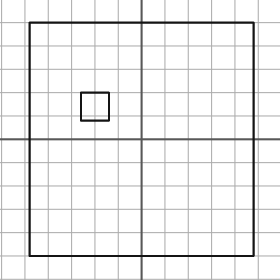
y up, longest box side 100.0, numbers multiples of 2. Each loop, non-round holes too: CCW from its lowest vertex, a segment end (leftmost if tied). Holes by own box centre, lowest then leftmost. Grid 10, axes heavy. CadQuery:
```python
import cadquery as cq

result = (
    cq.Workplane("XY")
    .moveTo(-48.0, -50.0)
    .lineTo(48.0, -50.0)
    .lineTo(48.0, 50.0)
    .lineTo(-48.0, 50.0)
    .close()
    .moveTo(-26.0, 8.0)
    .lineTo(-14.0, 8.0)
    .lineTo(-14.0, 20.0)
    .lineTo(-26.0, 20.0)
    .close()
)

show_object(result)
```